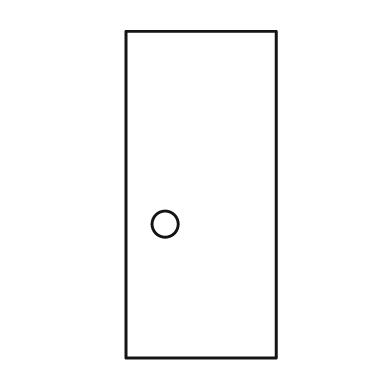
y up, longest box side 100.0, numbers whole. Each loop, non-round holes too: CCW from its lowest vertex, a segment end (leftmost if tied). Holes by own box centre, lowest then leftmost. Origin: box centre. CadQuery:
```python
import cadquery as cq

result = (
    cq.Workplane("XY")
    .moveTo(-23.0, -50.0)
    .lineTo(23.0, -50.0)
    .lineTo(23.0, 50.0)
    .lineTo(-23.0, 50.0)
    .close()
    .moveTo(-11.0, -9.0)
    .circle(4.0)
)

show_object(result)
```